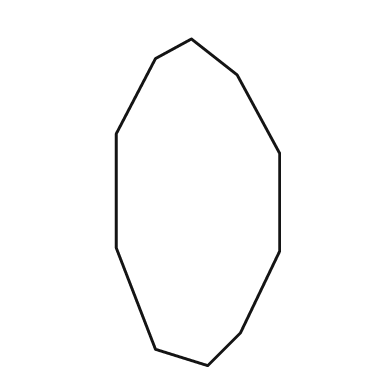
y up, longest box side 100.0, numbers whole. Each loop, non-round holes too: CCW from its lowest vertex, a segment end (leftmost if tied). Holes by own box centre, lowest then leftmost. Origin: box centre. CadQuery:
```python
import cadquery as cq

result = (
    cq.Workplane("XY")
    .moveTo(3.0, -50.0)
    .lineTo(13.0, -40.0)
    .lineTo(25.0, -15.0)
    .lineTo(25.0, 15.0)
    .lineTo(12.0, 39.0)
    .lineTo(-2.0, 50.0)
    .lineTo(-13.0, 44.0)
    .lineTo(-25.0, 21.0)
    .lineTo(-25.0, -14.0)
    .lineTo(-13.0, -45.0)
    .close()
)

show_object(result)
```